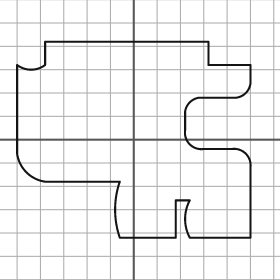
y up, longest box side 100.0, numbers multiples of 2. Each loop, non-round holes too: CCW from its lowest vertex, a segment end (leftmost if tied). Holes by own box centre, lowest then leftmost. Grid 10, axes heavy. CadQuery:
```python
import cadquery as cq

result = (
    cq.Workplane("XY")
    .moveTo(-6.0, -42.0)
    .lineTo(18.0, -42.0)
    .lineTo(18.0, -26.0)
    .lineTo(24.0, -26.0)
    .threePointArc((22.0, -34.0), (24.0, -42.0))
    .lineTo(50.0, -42.0)
    .lineTo(50.0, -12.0)
    .threePointArc((48.0, -6.0), (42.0, -4.0))
    .lineTo(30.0, -4.0)
    .threePointArc((24.0, -2.0), (22.0, 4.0))
    .lineTo(22.0, 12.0)
    .threePointArc((24.0, 16.0), (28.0, 18.0))
    .lineTo(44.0, 18.0)
    .threePointArc((48.0, 20.0), (50.0, 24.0))
    .lineTo(50.0, 32.0)
    .lineTo(32.0, 32.0)
    .lineTo(32.0, 42.0)
    .lineTo(-38.0, 42.0)
    .lineTo(-38.0, 32.0)
    .threePointArc((-44.0, 30.0), (-50.0, 32.0))
    .lineTo(-50.0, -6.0)
    .threePointArc((-46.0, -14.0), (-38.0, -18.0))
    .lineTo(-6.0, -18.0)
    .threePointArc((-8.0, -30.0), (-6.0, -42.0))
    .close()
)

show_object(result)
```